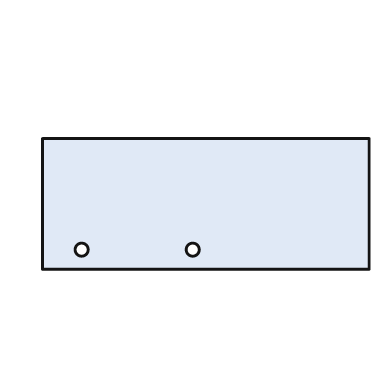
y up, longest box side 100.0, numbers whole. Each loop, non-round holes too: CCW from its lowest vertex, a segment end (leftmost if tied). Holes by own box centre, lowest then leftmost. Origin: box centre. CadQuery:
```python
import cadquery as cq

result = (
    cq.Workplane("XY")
    .moveTo(-50.0, -20.0)
    .lineTo(50.0, -20.0)
    .lineTo(50.0, 20.0)
    .lineTo(-50.0, 20.0)
    .close()
    .moveTo(-38.0, -14.0)
    .circle(2.0)
    .moveTo(-4.0, -14.0)
    .circle(2.0)
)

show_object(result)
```